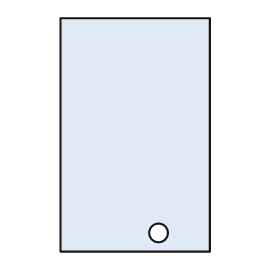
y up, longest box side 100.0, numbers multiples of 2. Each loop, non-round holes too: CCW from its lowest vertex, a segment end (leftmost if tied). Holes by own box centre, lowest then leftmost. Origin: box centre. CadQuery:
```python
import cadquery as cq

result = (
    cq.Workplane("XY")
    .moveTo(-32.0, -50.0)
    .lineTo(32.0, -50.0)
    .lineTo(32.0, 50.0)
    .lineTo(-32.0, 50.0)
    .close()
    .moveTo(10.0, -42.0)
    .circle(4.0)
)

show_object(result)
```